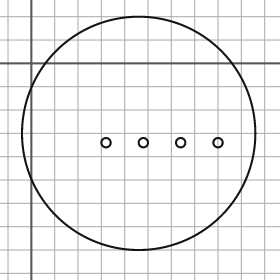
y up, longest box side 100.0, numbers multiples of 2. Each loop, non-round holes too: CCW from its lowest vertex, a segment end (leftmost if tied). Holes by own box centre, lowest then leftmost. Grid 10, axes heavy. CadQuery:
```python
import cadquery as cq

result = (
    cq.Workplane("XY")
    .moveTo(46.0, -30.0)
    .circle(50.0)
    .moveTo(32.0, -34.0)
    .circle(2.0)
    .moveTo(48.0, -34.0)
    .circle(2.0)
    .moveTo(64.0, -34.0)
    .circle(2.0)
    .moveTo(80.0, -34.0)
    .circle(2.0)
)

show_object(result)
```